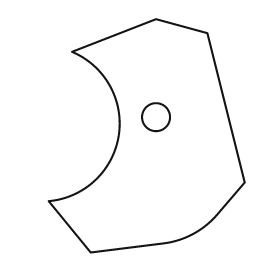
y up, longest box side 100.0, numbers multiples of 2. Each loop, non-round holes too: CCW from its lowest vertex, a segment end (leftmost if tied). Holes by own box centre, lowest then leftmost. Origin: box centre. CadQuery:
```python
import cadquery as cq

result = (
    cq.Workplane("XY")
    .moveTo(-24.0, -50.0)
    .lineTo(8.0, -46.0)
    .threePointArc((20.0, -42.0), (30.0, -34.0))
    .lineTo(42.0, -20.0)
    .lineTo(26.0, 44.0)
    .lineTo(4.0, 50.0)
    .lineTo(-32.0, 36.0)
    .threePointArc((-12.0, 0.0), (-42.0, -28.0))
    .close()
    .moveTo(4.0, 8.0)
    .circle(6.0)
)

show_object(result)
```